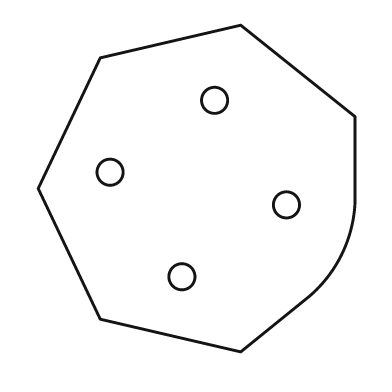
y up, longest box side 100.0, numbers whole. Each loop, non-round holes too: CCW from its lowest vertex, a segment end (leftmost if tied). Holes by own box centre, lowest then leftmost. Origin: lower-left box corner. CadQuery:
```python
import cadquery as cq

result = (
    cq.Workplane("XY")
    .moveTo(62.0, 0.0)
    .lineTo(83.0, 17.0)
    .threePointArc((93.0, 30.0), (97.0, 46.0))
    .lineTo(97.0, 72.0)
    .lineTo(62.0, 100.0)
    .lineTo(19.0, 90.0)
    .lineTo(0.0, 50.0)
    .lineTo(19.0, 10.0)
    .close()
    .moveTo(44.0, 23.0)
    .circle(4.0)
    .moveTo(76.0, 45.0)
    .circle(4.0)
    .moveTo(22.0, 55.0)
    .circle(4.0)
    .moveTo(54.0, 77.0)
    .circle(4.0)
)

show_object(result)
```